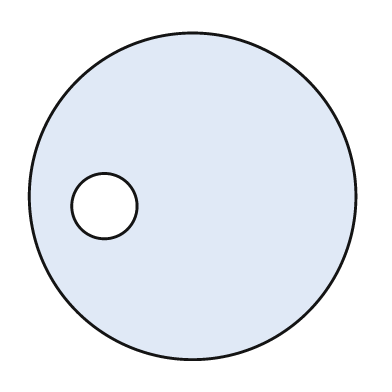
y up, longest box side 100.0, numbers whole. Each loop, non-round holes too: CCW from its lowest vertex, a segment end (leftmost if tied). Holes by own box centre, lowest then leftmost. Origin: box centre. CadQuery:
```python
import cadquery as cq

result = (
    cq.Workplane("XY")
    .moveTo(0.0, 0.0)
    .circle(50.0)
    .moveTo(-27.0, -3.0)
    .circle(10.0)
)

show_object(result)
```